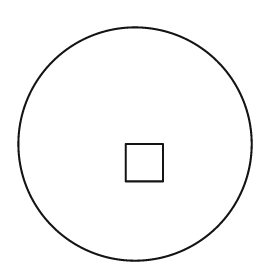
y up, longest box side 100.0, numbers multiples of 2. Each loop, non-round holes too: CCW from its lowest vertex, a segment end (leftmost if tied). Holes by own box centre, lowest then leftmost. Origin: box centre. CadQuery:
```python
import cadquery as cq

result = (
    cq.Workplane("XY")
    .moveTo(0.0, 0.0)
    .circle(50.0)
    .moveTo(-4.0, -16.0)
    .lineTo(12.0, -16.0)
    .lineTo(12.0, 0.0)
    .lineTo(-4.0, 0.0)
    .close()
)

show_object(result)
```